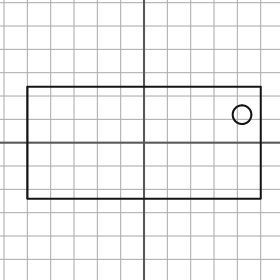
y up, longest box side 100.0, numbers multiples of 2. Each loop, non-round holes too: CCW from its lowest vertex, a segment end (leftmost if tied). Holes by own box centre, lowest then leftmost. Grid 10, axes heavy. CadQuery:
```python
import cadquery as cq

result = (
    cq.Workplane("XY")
    .moveTo(-50.0, -24.0)
    .lineTo(50.0, -24.0)
    .lineTo(50.0, 24.0)
    .lineTo(-50.0, 24.0)
    .close()
    .moveTo(42.0, 12.0)
    .circle(4.0)
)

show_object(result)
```